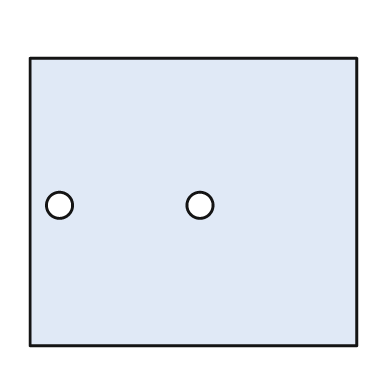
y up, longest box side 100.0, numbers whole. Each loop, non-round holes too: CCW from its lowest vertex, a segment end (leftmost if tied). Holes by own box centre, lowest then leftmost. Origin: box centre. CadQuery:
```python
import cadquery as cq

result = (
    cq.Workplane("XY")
    .moveTo(-50.0, -44.0)
    .lineTo(50.0, -44.0)
    .lineTo(50.0, 44.0)
    .lineTo(-50.0, 44.0)
    .close()
    .moveTo(-41.0, -1.0)
    .circle(4.0)
    .moveTo(2.0, -1.0)
    .circle(4.0)
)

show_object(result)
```